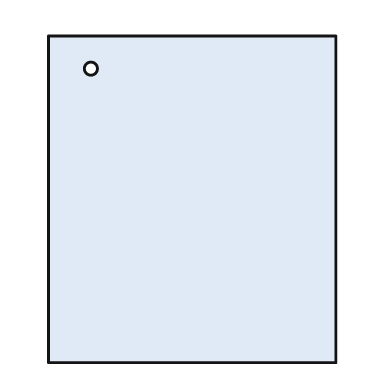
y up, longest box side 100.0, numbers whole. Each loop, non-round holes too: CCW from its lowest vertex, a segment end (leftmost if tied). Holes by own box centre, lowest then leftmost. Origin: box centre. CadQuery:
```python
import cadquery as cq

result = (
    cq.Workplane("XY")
    .moveTo(-44.0, -50.0)
    .lineTo(44.0, -50.0)
    .lineTo(44.0, 50.0)
    .lineTo(-44.0, 50.0)
    .close()
    .moveTo(-31.0, 40.0)
    .circle(2.0)
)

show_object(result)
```